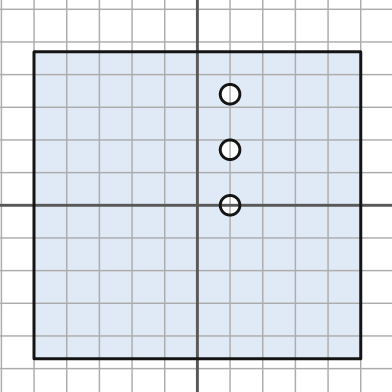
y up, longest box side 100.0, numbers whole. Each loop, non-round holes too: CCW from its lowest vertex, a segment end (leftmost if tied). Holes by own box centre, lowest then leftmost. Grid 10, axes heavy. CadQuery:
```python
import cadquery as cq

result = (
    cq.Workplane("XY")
    .moveTo(-50.0, -47.0)
    .lineTo(50.0, -47.0)
    .lineTo(50.0, 47.0)
    .lineTo(-50.0, 47.0)
    .close()
    .moveTo(10.0, 0.0)
    .circle(3.0)
    .moveTo(10.0, 17.0)
    .circle(3.0)
    .moveTo(10.0, 34.0)
    .circle(3.0)
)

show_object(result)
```